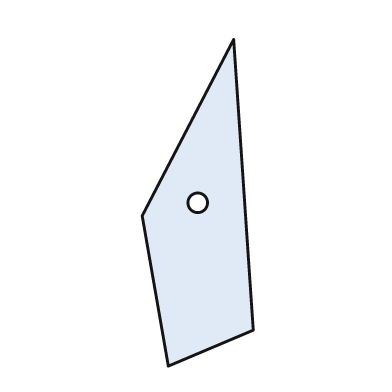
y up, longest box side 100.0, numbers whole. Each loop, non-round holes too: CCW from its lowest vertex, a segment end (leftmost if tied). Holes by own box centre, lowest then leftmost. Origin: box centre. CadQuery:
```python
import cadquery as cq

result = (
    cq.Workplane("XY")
    .moveTo(-9.0, -50.0)
    .lineTo(17.0, -39.0)
    .lineTo(11.0, 50.0)
    .lineTo(-17.0, -4.0)
    .close()
    .moveTo(0.0, 0.0)
    .circle(3.0)
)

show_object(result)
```